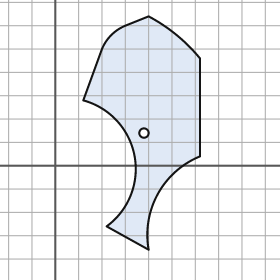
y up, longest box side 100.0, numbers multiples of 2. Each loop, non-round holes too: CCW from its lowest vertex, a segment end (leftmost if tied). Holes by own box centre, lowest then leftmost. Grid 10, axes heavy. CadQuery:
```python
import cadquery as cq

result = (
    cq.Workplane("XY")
    .moveTo(40.0, -36.0)
    .threePointArc((44.0, -12.0), (62.0, 4.0))
    .lineTo(62.0, 46.0)
    .threePointArc((52.0, 56.0), (40.0, 64.0))
    .lineTo(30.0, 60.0)
    .threePointArc((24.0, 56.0), (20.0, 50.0))
    .lineTo(12.0, 28.0)
    .threePointArc((34.0, 4.0), (22.0, -26.0))
    .close()
    .moveTo(38.0, 14.0)
    .circle(2.0)
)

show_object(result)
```